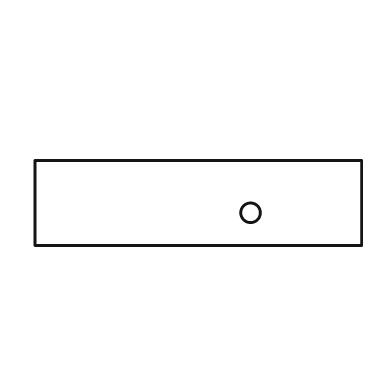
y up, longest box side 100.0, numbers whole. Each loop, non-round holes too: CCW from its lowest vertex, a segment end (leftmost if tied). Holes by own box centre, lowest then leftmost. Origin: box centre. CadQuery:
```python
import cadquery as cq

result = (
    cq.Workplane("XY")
    .moveTo(-50.0, -13.0)
    .lineTo(50.0, -13.0)
    .lineTo(50.0, 13.0)
    .lineTo(-50.0, 13.0)
    .close()
    .moveTo(16.0, -3.0)
    .circle(3.0)
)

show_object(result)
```